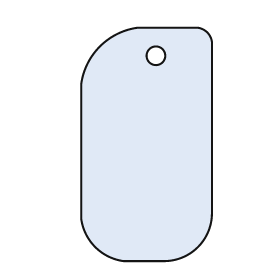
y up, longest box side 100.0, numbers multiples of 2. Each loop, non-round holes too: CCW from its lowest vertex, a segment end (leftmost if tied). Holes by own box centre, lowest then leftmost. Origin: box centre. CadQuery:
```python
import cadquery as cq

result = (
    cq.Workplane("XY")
    .moveTo(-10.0, -50.0)
    .lineTo(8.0, -50.0)
    .threePointArc((22.0, -44.0), (28.0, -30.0))
    .lineTo(28.0, 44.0)
    .threePointArc((26.0, 48.0), (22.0, 50.0))
    .lineTo(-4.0, 50.0)
    .threePointArc((-20.0, 42.0), (-28.0, 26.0))
    .lineTo(-28.0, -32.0)
    .threePointArc((-22.0, -44.0), (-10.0, -50.0))
    .close()
    .moveTo(4.0, 38.0)
    .circle(4.0)
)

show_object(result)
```